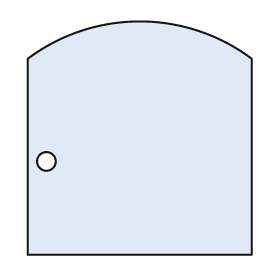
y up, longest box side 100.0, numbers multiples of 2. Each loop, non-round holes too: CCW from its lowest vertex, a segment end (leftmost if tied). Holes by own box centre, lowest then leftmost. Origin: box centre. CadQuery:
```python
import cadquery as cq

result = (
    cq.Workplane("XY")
    .moveTo(-48.0, -50.0)
    .lineTo(48.0, -50.0)
    .lineTo(48.0, 34.0)
    .threePointArc((0.0, 50.0), (-48.0, 34.0))
    .close()
    .moveTo(-40.0, -10.0)
    .circle(4.0)
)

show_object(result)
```